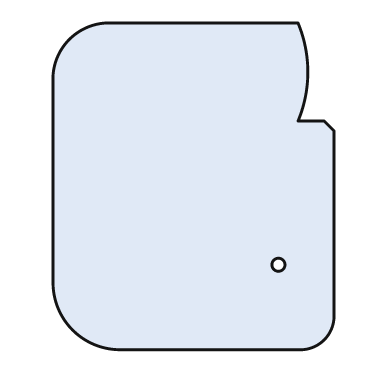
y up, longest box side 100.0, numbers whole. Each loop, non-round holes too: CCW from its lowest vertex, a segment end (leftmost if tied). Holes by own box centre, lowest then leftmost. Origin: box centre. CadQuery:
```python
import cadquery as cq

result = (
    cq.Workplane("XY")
    .moveTo(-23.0, -50.0)
    .lineTo(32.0, -50.0)
    .threePointArc((40.0, -47.0), (43.0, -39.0))
    .lineTo(43.0, 17.0)
    .lineTo(40.0, 20.0)
    .lineTo(32.0, 20.0)
    .threePointArc((35.0, 35.0), (32.0, 50.0))
    .lineTo(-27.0, 50.0)
    .threePointArc((-38.0, 45.0), (-43.0, 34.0))
    .lineTo(-43.0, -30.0)
    .threePointArc((-37.0, -44.0), (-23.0, -50.0))
    .close()
    .moveTo(26.0, -24.0)
    .circle(2.0)
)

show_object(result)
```